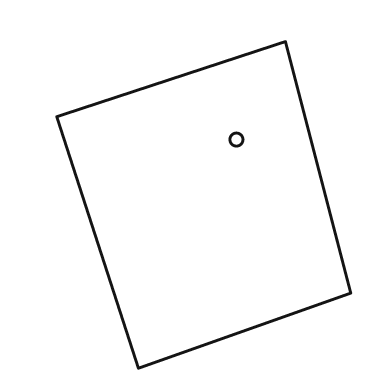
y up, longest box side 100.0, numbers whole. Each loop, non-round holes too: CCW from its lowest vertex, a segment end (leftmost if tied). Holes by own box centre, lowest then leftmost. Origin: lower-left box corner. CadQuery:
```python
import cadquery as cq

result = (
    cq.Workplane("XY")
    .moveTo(25.0, 0.0)
    .lineTo(90.0, 23.0)
    .lineTo(70.0, 100.0)
    .lineTo(0.0, 77.0)
    .close()
    .moveTo(55.0, 70.0)
    .circle(2.0)
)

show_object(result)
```